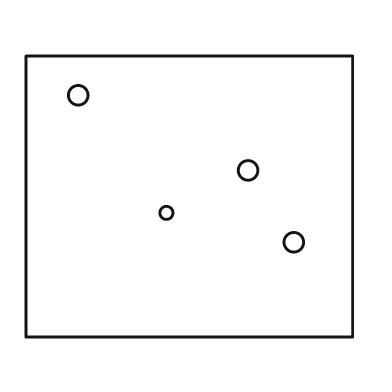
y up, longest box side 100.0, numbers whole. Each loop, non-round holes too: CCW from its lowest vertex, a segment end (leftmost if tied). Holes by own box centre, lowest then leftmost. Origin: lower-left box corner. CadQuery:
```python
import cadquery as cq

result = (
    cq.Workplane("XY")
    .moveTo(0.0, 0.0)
    .lineTo(100.0, 0.0)
    .lineTo(100.0, 86.0)
    .lineTo(0.0, 86.0)
    .close()
    .moveTo(82.0, 29.0)
    .circle(3.0)
    .moveTo(43.0, 38.0)
    .circle(2.0)
    .moveTo(68.0, 51.0)
    .circle(3.0)
    .moveTo(16.0, 74.0)
    .circle(3.0)
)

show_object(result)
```